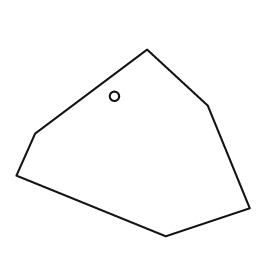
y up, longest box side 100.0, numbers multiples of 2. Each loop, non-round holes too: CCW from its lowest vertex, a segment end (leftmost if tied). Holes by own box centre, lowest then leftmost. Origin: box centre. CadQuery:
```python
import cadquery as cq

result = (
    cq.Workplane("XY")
    .moveTo(14.0, -40.0)
    .lineTo(50.0, -28.0)
    .lineTo(32.0, 16.0)
    .lineTo(6.0, 40.0)
    .lineTo(-42.0, 4.0)
    .lineTo(-50.0, -14.0)
    .close()
    .moveTo(-8.0, 20.0)
    .circle(2.0)
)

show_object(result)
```